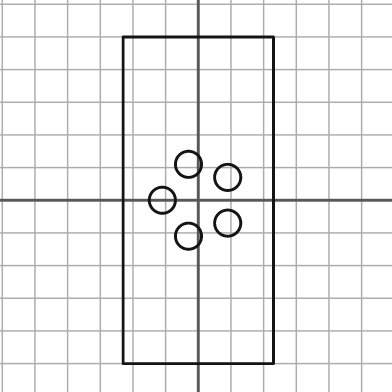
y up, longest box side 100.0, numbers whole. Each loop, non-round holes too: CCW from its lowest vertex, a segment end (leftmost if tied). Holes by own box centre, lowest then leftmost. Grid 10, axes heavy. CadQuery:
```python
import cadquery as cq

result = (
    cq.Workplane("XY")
    .moveTo(-23.0, -50.0)
    .lineTo(23.0, -50.0)
    .lineTo(23.0, 50.0)
    .lineTo(-23.0, 50.0)
    .close()
    .moveTo(-3.0, -11.0)
    .circle(4.0)
    .moveTo(9.0, -7.0)
    .circle(4.0)
    .moveTo(-11.0, 0.0)
    .circle(4.0)
    .moveTo(9.0, 7.0)
    .circle(4.0)
    .moveTo(-3.0, 11.0)
    .circle(4.0)
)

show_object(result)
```